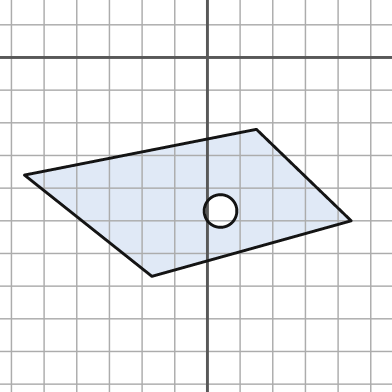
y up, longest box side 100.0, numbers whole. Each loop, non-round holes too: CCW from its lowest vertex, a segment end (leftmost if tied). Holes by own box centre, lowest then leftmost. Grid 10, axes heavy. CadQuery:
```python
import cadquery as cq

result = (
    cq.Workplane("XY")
    .moveTo(-17.0, -67.0)
    .lineTo(44.0, -50.0)
    .lineTo(15.0, -22.0)
    .lineTo(-56.0, -36.0)
    .close()
    .moveTo(4.0, -47.0)
    .circle(5.0)
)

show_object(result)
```